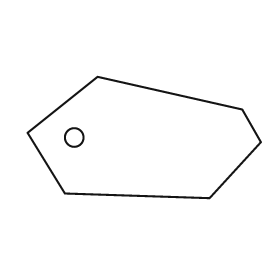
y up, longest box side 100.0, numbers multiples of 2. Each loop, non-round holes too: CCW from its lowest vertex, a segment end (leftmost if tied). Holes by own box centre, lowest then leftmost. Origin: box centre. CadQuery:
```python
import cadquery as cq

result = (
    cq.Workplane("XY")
    .moveTo(28.0, -26.0)
    .lineTo(50.0, -2.0)
    .lineTo(42.0, 12.0)
    .lineTo(-20.0, 26.0)
    .lineTo(-50.0, 2.0)
    .lineTo(-34.0, -24.0)
    .close()
    .moveTo(-30.0, 0.0)
    .circle(4.0)
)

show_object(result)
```